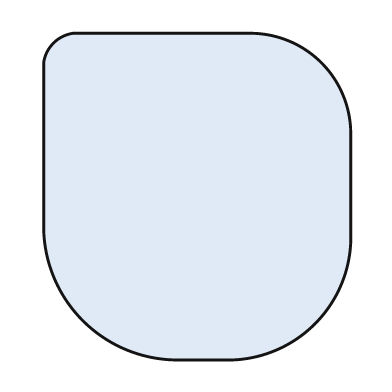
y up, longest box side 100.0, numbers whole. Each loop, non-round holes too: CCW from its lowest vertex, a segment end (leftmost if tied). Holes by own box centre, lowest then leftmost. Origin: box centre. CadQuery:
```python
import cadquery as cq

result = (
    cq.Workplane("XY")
    .moveTo(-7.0, -50.0)
    .lineTo(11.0, -50.0)
    .threePointArc((36.0, -39.0), (47.0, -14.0))
    .lineTo(47.0, 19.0)
    .threePointArc((38.0, 41.0), (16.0, 50.0))
    .lineTo(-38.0, 50.0)
    .threePointArc((-44.0, 47.0), (-47.0, 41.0))
    .lineTo(-47.0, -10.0)
    .threePointArc((-35.0, -38.0), (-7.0, -50.0))
    .close()
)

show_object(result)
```